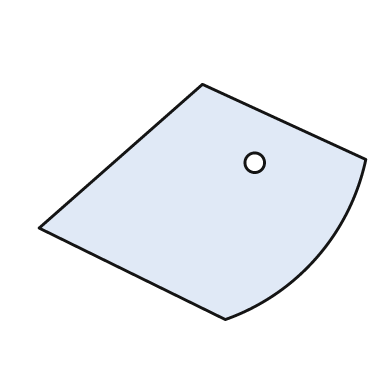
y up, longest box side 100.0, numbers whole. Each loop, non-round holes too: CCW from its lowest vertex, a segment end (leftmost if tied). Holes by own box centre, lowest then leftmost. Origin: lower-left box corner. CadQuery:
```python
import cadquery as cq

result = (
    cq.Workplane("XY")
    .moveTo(57.0, 0.0)
    .threePointArc((85.0, 19.0), (100.0, 49.0))
    .lineTo(50.0, 72.0)
    .lineTo(0.0, 28.0)
    .close()
    .moveTo(66.0, 48.0)
    .circle(3.0)
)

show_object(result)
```